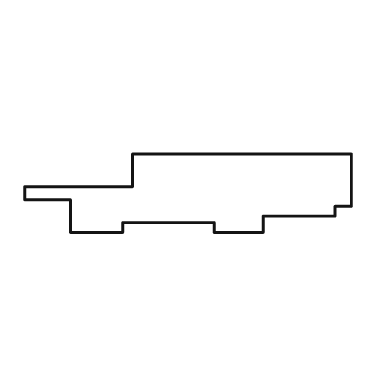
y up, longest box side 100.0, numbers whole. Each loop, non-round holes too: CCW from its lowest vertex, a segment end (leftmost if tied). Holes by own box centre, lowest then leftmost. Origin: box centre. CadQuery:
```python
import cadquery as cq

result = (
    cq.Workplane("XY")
    .moveTo(-36.0, -12.0)
    .lineTo(-20.0, -12.0)
    .lineTo(-20.0, -9.0)
    .lineTo(8.0, -9.0)
    .lineTo(8.0, -12.0)
    .lineTo(23.0, -12.0)
    .lineTo(23.0, -7.0)
    .lineTo(45.0, -7.0)
    .lineTo(45.0, -4.0)
    .lineTo(50.0, -4.0)
    .lineTo(50.0, 12.0)
    .lineTo(-17.0, 12.0)
    .lineTo(-17.0, 2.0)
    .lineTo(-50.0, 2.0)
    .lineTo(-50.0, -2.0)
    .lineTo(-36.0, -2.0)
    .close()
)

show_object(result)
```